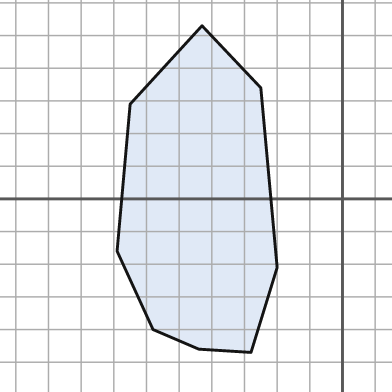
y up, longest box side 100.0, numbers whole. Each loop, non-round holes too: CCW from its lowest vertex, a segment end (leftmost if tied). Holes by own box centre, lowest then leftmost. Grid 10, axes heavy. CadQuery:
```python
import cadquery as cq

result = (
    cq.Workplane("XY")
    .moveTo(-28.0, -47.0)
    .lineTo(-20.0, -21.0)
    .lineTo(-25.0, 34.0)
    .lineTo(-43.0, 53.0)
    .lineTo(-65.0, 29.0)
    .lineTo(-69.0, -16.0)
    .lineTo(-58.0, -40.0)
    .lineTo(-44.0, -46.0)
    .close()
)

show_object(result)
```